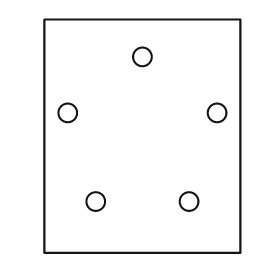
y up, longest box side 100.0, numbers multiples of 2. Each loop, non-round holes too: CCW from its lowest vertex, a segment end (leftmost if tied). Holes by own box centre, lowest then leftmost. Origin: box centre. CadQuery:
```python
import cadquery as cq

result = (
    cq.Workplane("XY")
    .moveTo(-42.0, -50.0)
    .lineTo(42.0, -50.0)
    .lineTo(42.0, 50.0)
    .lineTo(-42.0, 50.0)
    .close()
    .moveTo(-20.0, -28.0)
    .circle(4.0)
    .moveTo(20.0, -28.0)
    .circle(4.0)
    .moveTo(-32.0, 10.0)
    .circle(4.0)
    .moveTo(32.0, 10.0)
    .circle(4.0)
    .moveTo(0.0, 34.0)
    .circle(4.0)
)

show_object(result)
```